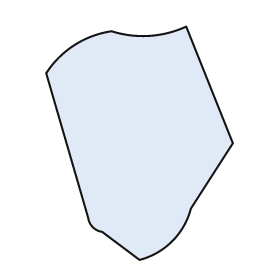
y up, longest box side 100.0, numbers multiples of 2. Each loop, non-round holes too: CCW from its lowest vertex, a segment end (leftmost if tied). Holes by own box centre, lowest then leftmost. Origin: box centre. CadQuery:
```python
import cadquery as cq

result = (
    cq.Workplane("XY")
    .moveTo(0.0, -50.0)
    .threePointArc((14.0, -42.0), (22.0, -28.0))
    .lineTo(40.0, 0.0)
    .lineTo(20.0, 50.0)
    .threePointArc((4.0, 46.0), (-12.0, 48.0))
    .threePointArc((-28.0, 42.0), (-40.0, 30.0))
    .lineTo(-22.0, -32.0)
    .threePointArc((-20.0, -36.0), (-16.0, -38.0))
    .close()
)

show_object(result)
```